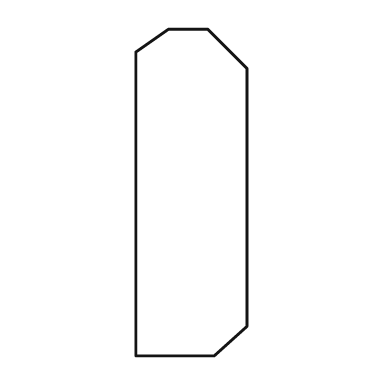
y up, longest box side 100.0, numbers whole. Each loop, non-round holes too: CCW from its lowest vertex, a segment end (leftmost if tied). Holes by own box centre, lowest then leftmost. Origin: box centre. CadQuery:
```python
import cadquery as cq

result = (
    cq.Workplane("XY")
    .moveTo(-17.0, -50.0)
    .lineTo(7.0, -50.0)
    .lineTo(17.0, -41.0)
    .lineTo(17.0, 38.0)
    .lineTo(5.0, 50.0)
    .lineTo(-7.0, 50.0)
    .lineTo(-17.0, 43.0)
    .close()
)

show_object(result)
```